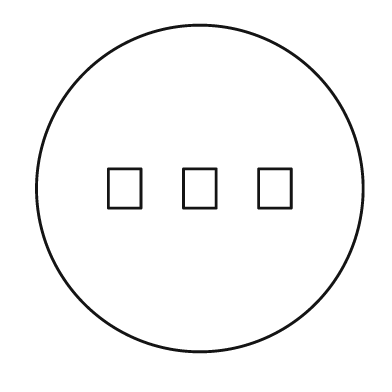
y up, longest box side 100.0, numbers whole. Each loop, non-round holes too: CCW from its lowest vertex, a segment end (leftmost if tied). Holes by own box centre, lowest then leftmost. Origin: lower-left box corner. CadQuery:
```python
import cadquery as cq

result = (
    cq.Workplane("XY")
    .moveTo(50.0, 50.0)
    .circle(50.0)
    .moveTo(22.0, 44.0)
    .lineTo(32.0, 44.0)
    .lineTo(32.0, 56.0)
    .lineTo(22.0, 56.0)
    .close()
    .moveTo(45.0, 44.0)
    .lineTo(55.0, 44.0)
    .lineTo(55.0, 56.0)
    .lineTo(45.0, 56.0)
    .close()
    .moveTo(68.0, 44.0)
    .lineTo(78.0, 44.0)
    .lineTo(78.0, 56.0)
    .lineTo(68.0, 56.0)
    .close()
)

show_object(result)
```